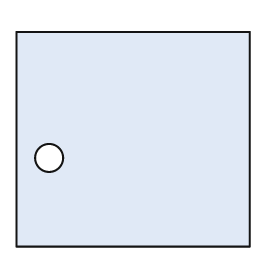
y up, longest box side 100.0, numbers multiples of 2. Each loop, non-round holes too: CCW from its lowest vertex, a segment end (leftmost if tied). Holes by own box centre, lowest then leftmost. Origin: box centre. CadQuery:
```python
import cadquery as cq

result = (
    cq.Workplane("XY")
    .moveTo(-50.0, -46.0)
    .lineTo(50.0, -46.0)
    .lineTo(50.0, 46.0)
    .lineTo(-50.0, 46.0)
    .close()
    .moveTo(-36.0, -8.0)
    .circle(6.0)
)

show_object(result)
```